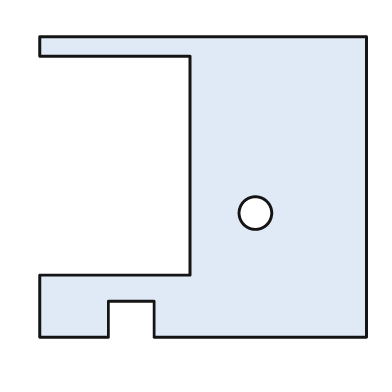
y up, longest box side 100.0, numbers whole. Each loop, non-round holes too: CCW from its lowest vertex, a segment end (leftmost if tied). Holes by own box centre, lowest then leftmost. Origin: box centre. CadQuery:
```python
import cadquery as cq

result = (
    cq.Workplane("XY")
    .moveTo(-50.0, -46.0)
    .lineTo(-29.0, -46.0)
    .lineTo(-29.0, -35.0)
    .lineTo(-15.0, -35.0)
    .lineTo(-15.0, -46.0)
    .lineTo(50.0, -46.0)
    .lineTo(50.0, 46.0)
    .lineTo(-50.0, 46.0)
    .lineTo(-50.0, 40.0)
    .lineTo(-4.0, 40.0)
    .lineTo(-4.0, -27.0)
    .lineTo(-50.0, -27.0)
    .close()
    .moveTo(16.0, -8.0)
    .circle(5.0)
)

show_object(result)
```